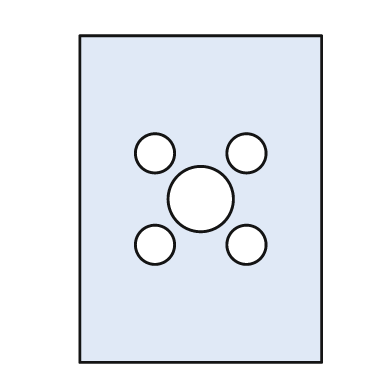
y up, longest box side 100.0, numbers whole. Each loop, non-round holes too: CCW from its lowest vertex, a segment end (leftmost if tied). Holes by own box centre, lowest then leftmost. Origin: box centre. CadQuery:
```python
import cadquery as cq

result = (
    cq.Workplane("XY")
    .moveTo(-37.0, -50.0)
    .lineTo(37.0, -50.0)
    .lineTo(37.0, 50.0)
    .lineTo(-37.0, 50.0)
    .close()
    .moveTo(-14.0, -14.0)
    .circle(6.0)
    .moveTo(14.0, -14.0)
    .circle(6.0)
    .moveTo(0.0, 0.0)
    .circle(10.0)
    .moveTo(-14.0, 14.0)
    .circle(6.0)
    .moveTo(14.0, 14.0)
    .circle(6.0)
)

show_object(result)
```